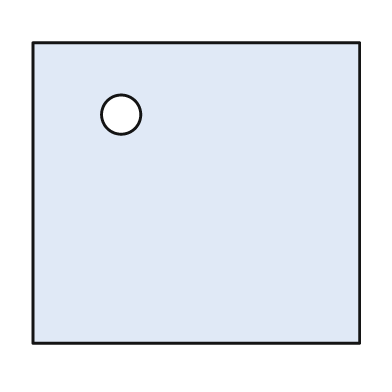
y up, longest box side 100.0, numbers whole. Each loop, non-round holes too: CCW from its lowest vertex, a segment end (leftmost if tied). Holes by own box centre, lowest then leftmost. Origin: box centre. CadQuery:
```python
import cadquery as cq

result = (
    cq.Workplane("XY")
    .moveTo(-50.0, -46.0)
    .lineTo(50.0, -46.0)
    .lineTo(50.0, 46.0)
    .lineTo(-50.0, 46.0)
    .close()
    .moveTo(-23.0, 24.0)
    .circle(6.0)
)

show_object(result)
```